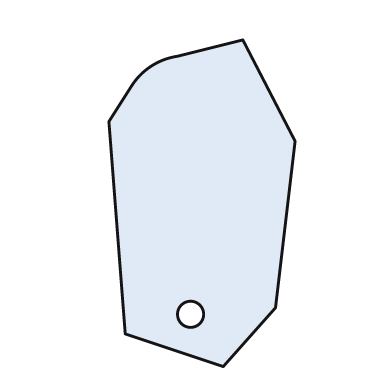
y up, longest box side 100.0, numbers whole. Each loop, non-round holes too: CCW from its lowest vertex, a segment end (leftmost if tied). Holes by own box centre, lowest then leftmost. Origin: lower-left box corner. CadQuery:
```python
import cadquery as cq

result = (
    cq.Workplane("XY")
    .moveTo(35.0, 0.0)
    .lineTo(51.0, 18.0)
    .lineTo(57.0, 69.0)
    .lineTo(41.0, 100.0)
    .lineTo(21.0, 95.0)
    .threePointArc((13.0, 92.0), (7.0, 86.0))
    .lineTo(0.0, 75.0)
    .lineTo(5.0, 10.0)
    .close()
    .moveTo(25.0, 16.0)
    .circle(4.0)
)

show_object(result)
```